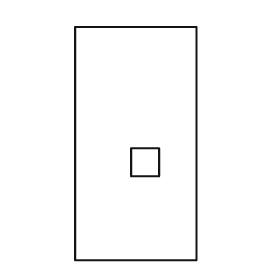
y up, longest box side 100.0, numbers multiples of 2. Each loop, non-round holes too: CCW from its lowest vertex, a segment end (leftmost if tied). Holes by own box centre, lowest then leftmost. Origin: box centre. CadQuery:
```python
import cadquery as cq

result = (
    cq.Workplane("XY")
    .moveTo(-26.0, -50.0)
    .lineTo(26.0, -50.0)
    .lineTo(26.0, 50.0)
    .lineTo(-26.0, 50.0)
    .close()
    .moveTo(-2.0, -14.0)
    .lineTo(10.0, -14.0)
    .lineTo(10.0, -2.0)
    .lineTo(-2.0, -2.0)
    .close()
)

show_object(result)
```